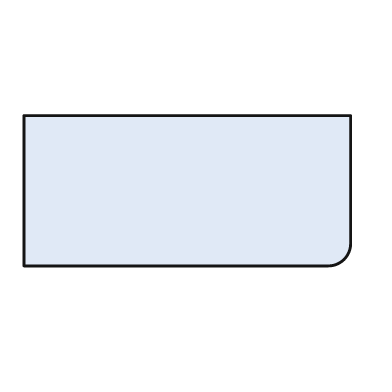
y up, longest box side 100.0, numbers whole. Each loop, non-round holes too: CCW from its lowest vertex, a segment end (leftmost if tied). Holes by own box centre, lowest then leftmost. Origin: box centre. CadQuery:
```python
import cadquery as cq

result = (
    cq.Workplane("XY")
    .moveTo(-50.0, -23.0)
    .lineTo(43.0, -23.0)
    .threePointArc((48.0, -21.0), (50.0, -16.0))
    .lineTo(50.0, 23.0)
    .lineTo(-50.0, 23.0)
    .close()
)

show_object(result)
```